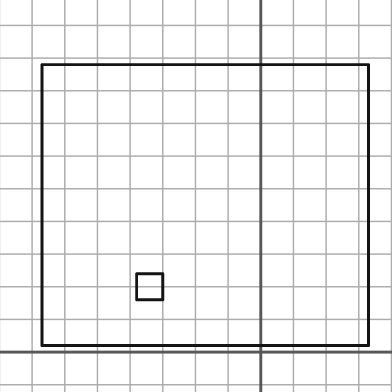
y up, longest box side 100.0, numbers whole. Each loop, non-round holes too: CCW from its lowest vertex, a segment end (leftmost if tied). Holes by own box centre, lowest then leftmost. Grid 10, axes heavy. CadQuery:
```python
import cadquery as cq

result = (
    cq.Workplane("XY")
    .moveTo(-67.0, 2.0)
    .lineTo(33.0, 2.0)
    .lineTo(33.0, 88.0)
    .lineTo(-67.0, 88.0)
    .close()
    .moveTo(-38.0, 16.0)
    .lineTo(-30.0, 16.0)
    .lineTo(-30.0, 24.0)
    .lineTo(-38.0, 24.0)
    .close()
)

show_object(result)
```